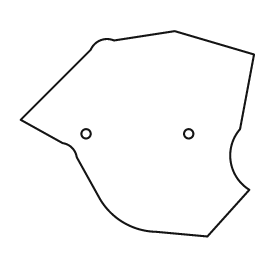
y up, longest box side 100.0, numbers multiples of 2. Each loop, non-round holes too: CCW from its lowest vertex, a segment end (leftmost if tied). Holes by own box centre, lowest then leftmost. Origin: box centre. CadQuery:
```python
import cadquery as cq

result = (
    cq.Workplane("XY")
    .moveTo(30.0, -44.0)
    .lineTo(48.0, -24.0)
    .threePointArc((40.0, -12.0), (44.0, 2.0))
    .lineTo(50.0, 34.0)
    .lineTo(16.0, 44.0)
    .lineTo(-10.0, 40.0)
    .threePointArc((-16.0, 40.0), (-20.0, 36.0))
    .lineTo(-50.0, 6.0)
    .lineTo(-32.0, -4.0)
    .threePointArc((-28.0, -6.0), (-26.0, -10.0))
    .lineTo(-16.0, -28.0)
    .threePointArc((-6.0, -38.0), (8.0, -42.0))
    .close()
    .moveTo(-22.0, 0.0)
    .circle(2.0)
    .moveTo(22.0, 0.0)
    .circle(2.0)
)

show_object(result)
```